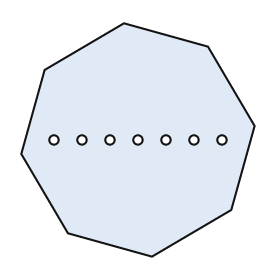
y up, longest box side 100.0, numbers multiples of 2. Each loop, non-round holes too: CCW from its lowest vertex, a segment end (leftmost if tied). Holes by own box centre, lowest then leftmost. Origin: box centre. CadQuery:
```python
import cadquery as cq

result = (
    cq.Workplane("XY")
    .moveTo(6.0, -50.0)
    .lineTo(40.0, -30.0)
    .lineTo(50.0, 6.0)
    .lineTo(30.0, 40.0)
    .lineTo(-6.0, 50.0)
    .lineTo(-40.0, 30.0)
    .lineTo(-50.0, -6.0)
    .lineTo(-30.0, -40.0)
    .close()
    .moveTo(-36.0, 0.0)
    .circle(2.0)
    .moveTo(-24.0, 0.0)
    .circle(2.0)
    .moveTo(-12.0, 0.0)
    .circle(2.0)
    .moveTo(0.0, 0.0)
    .circle(2.0)
    .moveTo(12.0, 0.0)
    .circle(2.0)
    .moveTo(24.0, 0.0)
    .circle(2.0)
    .moveTo(36.0, 0.0)
    .circle(2.0)
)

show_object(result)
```